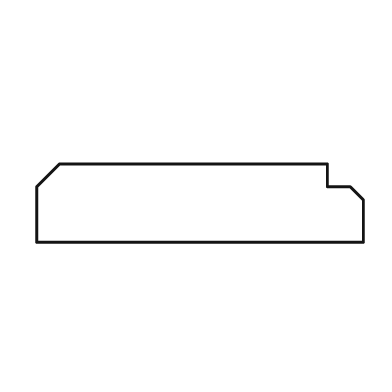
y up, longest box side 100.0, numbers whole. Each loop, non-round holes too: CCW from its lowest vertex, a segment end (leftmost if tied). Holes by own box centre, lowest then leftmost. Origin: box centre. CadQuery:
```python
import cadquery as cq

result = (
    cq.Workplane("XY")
    .moveTo(-50.0, -12.0)
    .lineTo(50.0, -12.0)
    .lineTo(50.0, 1.0)
    .lineTo(46.0, 5.0)
    .lineTo(39.0, 5.0)
    .lineTo(39.0, 12.0)
    .lineTo(-43.0, 12.0)
    .lineTo(-50.0, 5.0)
    .close()
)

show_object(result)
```